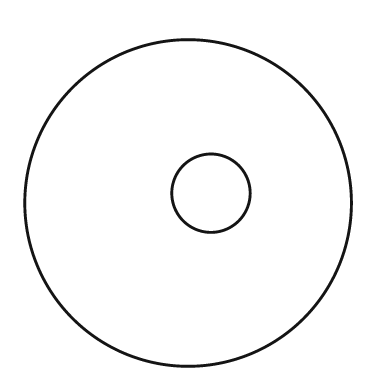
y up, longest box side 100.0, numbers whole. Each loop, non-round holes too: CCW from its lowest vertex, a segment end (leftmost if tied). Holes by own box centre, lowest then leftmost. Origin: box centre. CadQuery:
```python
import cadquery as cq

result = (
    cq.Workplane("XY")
    .moveTo(0.0, 0.0)
    .circle(50.0)
    .moveTo(7.0, 3.0)
    .circle(12.0)
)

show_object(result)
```